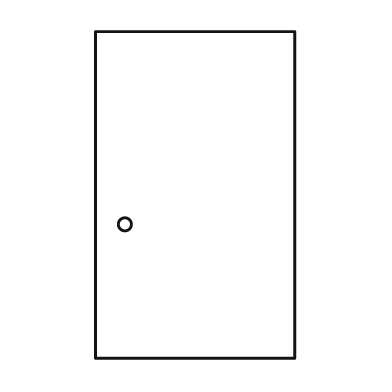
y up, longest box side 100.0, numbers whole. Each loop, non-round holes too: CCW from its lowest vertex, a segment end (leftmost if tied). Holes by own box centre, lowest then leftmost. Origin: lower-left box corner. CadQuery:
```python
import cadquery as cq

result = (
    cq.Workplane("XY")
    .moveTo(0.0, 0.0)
    .lineTo(61.0, 0.0)
    .lineTo(61.0, 100.0)
    .lineTo(0.0, 100.0)
    .close()
    .moveTo(9.0, 41.0)
    .circle(2.0)
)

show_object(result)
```